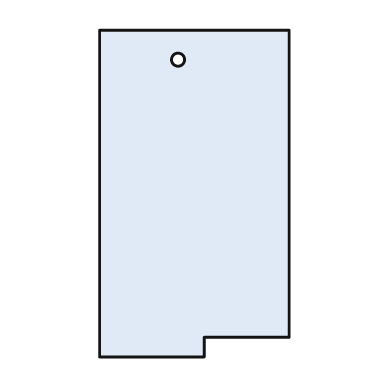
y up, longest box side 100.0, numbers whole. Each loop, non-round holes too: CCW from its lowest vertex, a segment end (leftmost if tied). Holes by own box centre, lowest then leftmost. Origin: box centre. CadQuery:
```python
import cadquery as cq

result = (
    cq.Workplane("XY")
    .moveTo(-29.0, -50.0)
    .lineTo(3.0, -50.0)
    .lineTo(3.0, -44.0)
    .lineTo(29.0, -44.0)
    .lineTo(29.0, 50.0)
    .lineTo(-29.0, 50.0)
    .close()
    .moveTo(-5.0, 41.0)
    .circle(2.0)
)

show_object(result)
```